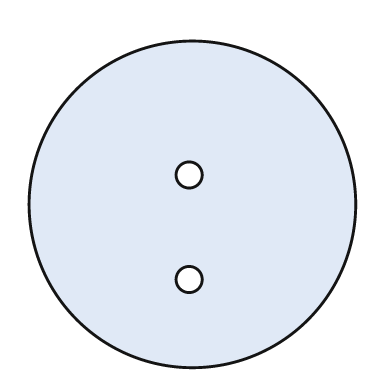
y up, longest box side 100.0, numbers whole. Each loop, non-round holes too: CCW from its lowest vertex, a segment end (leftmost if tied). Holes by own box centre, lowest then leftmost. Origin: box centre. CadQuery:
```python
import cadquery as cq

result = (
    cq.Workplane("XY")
    .moveTo(0.0, 0.0)
    .circle(50.0)
    .moveTo(-1.0, -23.0)
    .circle(4.0)
    .moveTo(-1.0, 9.0)
    .circle(4.0)
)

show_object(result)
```